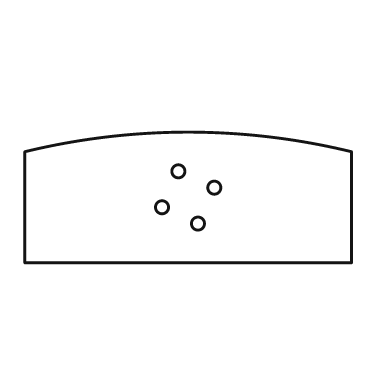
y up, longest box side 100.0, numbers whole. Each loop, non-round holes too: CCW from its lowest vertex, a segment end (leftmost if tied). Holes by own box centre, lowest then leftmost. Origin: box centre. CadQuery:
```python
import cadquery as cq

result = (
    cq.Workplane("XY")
    .moveTo(-50.0, -20.0)
    .lineTo(50.0, -20.0)
    .lineTo(50.0, 14.0)
    .threePointArc((0.0, 20.0), (-50.0, 14.0))
    .close()
    .moveTo(3.0, -8.0)
    .circle(2.0)
    .moveTo(-8.0, -3.0)
    .circle(2.0)
    .moveTo(8.0, 3.0)
    .circle(2.0)
    .moveTo(-3.0, 8.0)
    .circle(2.0)
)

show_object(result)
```